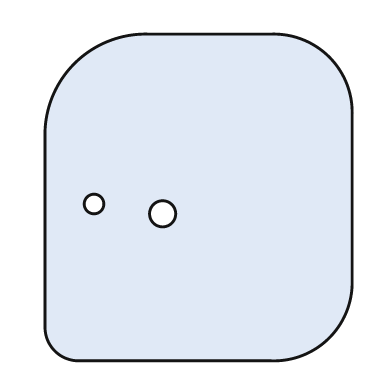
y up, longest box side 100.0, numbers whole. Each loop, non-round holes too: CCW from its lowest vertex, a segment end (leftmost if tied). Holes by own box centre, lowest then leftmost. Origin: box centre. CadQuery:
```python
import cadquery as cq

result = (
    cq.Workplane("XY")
    .moveTo(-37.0, -50.0)
    .lineTo(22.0, -50.0)
    .threePointArc((40.0, -43.0), (47.0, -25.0))
    .lineTo(47.0, 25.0)
    .threePointArc((40.0, 43.0), (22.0, 50.0))
    .lineTo(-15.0, 50.0)
    .threePointArc((-38.0, 41.0), (-47.0, 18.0))
    .lineTo(-47.0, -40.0)
    .threePointArc((-44.0, -47.0), (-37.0, -50.0))
    .close()
    .moveTo(-11.0, -5.0)
    .circle(4.0)
    .moveTo(-32.0, -2.0)
    .circle(3.0)
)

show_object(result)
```